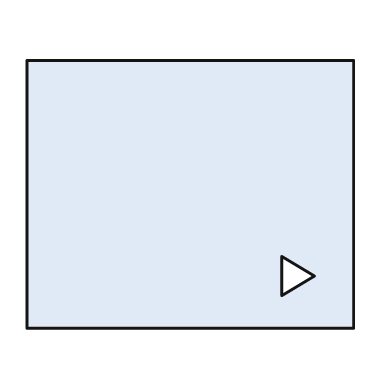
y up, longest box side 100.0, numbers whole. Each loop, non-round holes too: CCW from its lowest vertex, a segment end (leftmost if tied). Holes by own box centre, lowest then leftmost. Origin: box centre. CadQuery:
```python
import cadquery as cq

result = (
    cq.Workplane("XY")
    .moveTo(-50.0, -41.0)
    .lineTo(50.0, -41.0)
    .lineTo(50.0, 41.0)
    .lineTo(-50.0, 41.0)
    .close()
    .moveTo(28.0, -31.0)
    .lineTo(38.0, -25.0)
    .lineTo(28.0, -19.0)
    .close()
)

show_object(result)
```